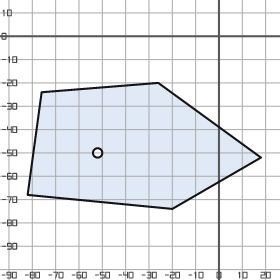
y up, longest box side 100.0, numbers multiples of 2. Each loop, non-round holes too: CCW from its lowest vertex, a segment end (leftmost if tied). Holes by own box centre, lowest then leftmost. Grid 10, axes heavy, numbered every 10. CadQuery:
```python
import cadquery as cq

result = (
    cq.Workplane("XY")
    .moveTo(-20.0, -74.0)
    .lineTo(18.0, -52.0)
    .lineTo(-26.0, -20.0)
    .lineTo(-76.0, -24.0)
    .lineTo(-82.0, -68.0)
    .close()
    .moveTo(-52.0, -50.0)
    .circle(2.0)
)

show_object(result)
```